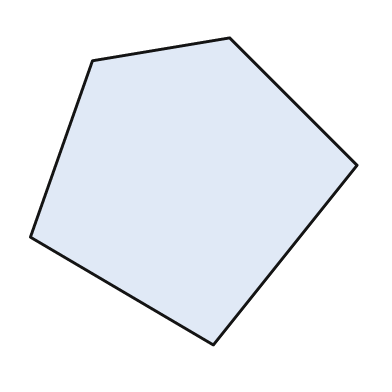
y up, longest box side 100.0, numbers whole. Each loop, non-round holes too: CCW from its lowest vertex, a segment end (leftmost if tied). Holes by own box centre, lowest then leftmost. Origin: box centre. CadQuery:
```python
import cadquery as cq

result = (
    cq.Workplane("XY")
    .moveTo(6.0, -47.0)
    .lineTo(50.0, 8.0)
    .lineTo(11.0, 47.0)
    .lineTo(-31.0, 40.0)
    .lineTo(-50.0, -14.0)
    .close()
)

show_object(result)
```